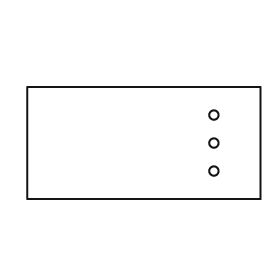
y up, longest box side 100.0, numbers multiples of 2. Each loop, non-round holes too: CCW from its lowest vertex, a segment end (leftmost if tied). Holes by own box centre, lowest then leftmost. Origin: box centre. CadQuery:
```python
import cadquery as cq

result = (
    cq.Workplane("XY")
    .moveTo(-50.0, -24.0)
    .lineTo(50.0, -24.0)
    .lineTo(50.0, 24.0)
    .lineTo(-50.0, 24.0)
    .close()
    .moveTo(30.0, -12.0)
    .circle(2.0)
    .moveTo(30.0, 0.0)
    .circle(2.0)
    .moveTo(30.0, 12.0)
    .circle(2.0)
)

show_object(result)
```